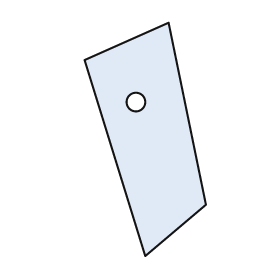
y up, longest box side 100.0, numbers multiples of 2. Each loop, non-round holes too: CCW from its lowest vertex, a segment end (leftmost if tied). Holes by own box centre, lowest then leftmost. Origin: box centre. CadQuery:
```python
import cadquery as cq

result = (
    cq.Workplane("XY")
    .moveTo(0.0, -50.0)
    .lineTo(26.0, -28.0)
    .lineTo(10.0, 50.0)
    .lineTo(-26.0, 34.0)
    .close()
    .moveTo(-4.0, 16.0)
    .circle(4.0)
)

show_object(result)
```